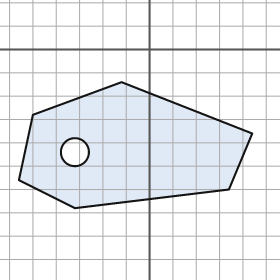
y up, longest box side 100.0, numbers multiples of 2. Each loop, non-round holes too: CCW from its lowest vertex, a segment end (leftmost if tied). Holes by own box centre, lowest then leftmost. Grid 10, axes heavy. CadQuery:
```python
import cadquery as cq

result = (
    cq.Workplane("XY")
    .moveTo(-32.0, -68.0)
    .lineTo(34.0, -60.0)
    .lineTo(44.0, -36.0)
    .lineTo(-12.0, -14.0)
    .lineTo(-50.0, -28.0)
    .lineTo(-56.0, -56.0)
    .close()
    .moveTo(-32.0, -44.0)
    .circle(6.0)
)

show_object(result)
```